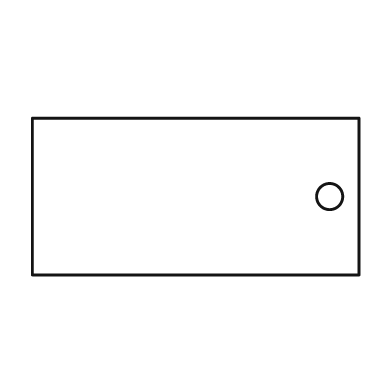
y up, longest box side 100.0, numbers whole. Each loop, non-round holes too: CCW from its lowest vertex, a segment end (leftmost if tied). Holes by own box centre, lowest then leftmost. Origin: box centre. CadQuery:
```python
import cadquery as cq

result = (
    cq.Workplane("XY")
    .moveTo(-50.0, -24.0)
    .lineTo(50.0, -24.0)
    .lineTo(50.0, 24.0)
    .lineTo(-50.0, 24.0)
    .close()
    .moveTo(41.0, 0.0)
    .circle(4.0)
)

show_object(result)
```